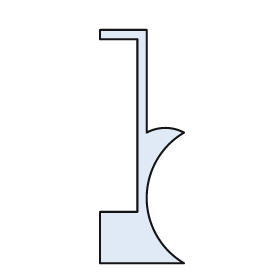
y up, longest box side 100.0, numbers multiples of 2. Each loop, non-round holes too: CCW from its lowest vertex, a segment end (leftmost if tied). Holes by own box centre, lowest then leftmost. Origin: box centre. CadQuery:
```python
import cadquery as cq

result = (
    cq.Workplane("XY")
    .moveTo(-18.0, -50.0)
    .lineTo(18.0, -50.0)
    .threePointArc((2.0, -22.0), (18.0, 6.0))
    .threePointArc((10.0, 8.0), (2.0, 6.0))
    .lineTo(2.0, 50.0)
    .lineTo(-18.0, 50.0)
    .lineTo(-18.0, 46.0)
    .lineTo(-2.0, 46.0)
    .lineTo(-2.0, -28.0)
    .lineTo(-18.0, -28.0)
    .close()
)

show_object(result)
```